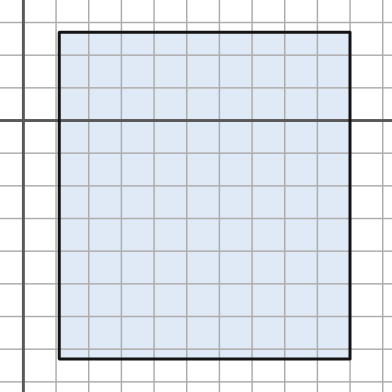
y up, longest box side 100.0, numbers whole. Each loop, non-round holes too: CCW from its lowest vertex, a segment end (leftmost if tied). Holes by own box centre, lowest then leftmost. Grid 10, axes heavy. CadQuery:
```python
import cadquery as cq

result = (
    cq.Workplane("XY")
    .moveTo(11.0, -73.0)
    .lineTo(100.0, -73.0)
    .lineTo(100.0, 27.0)
    .lineTo(11.0, 27.0)
    .close()
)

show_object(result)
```